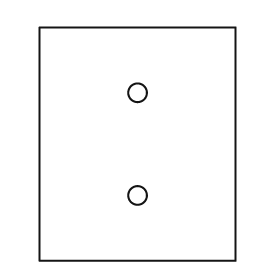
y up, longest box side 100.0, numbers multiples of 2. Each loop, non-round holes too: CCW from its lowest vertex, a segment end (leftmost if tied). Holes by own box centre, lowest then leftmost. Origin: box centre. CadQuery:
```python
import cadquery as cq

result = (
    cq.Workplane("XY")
    .moveTo(-42.0, -50.0)
    .lineTo(42.0, -50.0)
    .lineTo(42.0, 50.0)
    .lineTo(-42.0, 50.0)
    .close()
    .moveTo(0.0, -22.0)
    .circle(4.0)
    .moveTo(0.0, 22.0)
    .circle(4.0)
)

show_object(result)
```